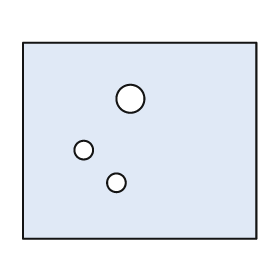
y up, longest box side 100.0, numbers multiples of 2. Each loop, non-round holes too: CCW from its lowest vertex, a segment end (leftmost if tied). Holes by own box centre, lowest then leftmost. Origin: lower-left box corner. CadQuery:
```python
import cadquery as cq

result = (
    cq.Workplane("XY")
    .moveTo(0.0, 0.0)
    .lineTo(100.0, 0.0)
    .lineTo(100.0, 84.0)
    .lineTo(0.0, 84.0)
    .close()
    .moveTo(40.0, 24.0)
    .circle(4.0)
    .moveTo(26.0, 38.0)
    .circle(4.0)
    .moveTo(46.0, 60.0)
    .circle(6.0)
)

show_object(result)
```